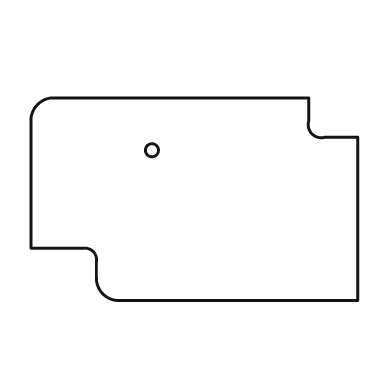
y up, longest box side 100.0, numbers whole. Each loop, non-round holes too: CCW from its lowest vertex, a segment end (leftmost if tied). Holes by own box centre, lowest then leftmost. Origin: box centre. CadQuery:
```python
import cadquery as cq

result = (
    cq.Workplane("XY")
    .moveTo(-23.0, -31.0)
    .lineTo(50.0, -31.0)
    .lineTo(50.0, 19.0)
    .lineTo(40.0, 19.0)
    .threePointArc((36.0, 20.0), (35.0, 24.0))
    .lineTo(35.0, 31.0)
    .lineTo(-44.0, 31.0)
    .threePointArc((-48.0, 29.0), (-50.0, 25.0))
    .lineTo(-50.0, -15.0)
    .lineTo(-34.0, -15.0)
    .threePointArc((-31.0, -16.0), (-30.0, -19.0))
    .lineTo(-30.0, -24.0)
    .threePointArc((-28.0, -29.0), (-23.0, -31.0))
    .close()
    .moveTo(-13.0, 15.0)
    .circle(2.0)
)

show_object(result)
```